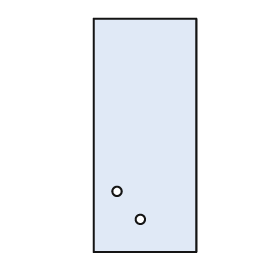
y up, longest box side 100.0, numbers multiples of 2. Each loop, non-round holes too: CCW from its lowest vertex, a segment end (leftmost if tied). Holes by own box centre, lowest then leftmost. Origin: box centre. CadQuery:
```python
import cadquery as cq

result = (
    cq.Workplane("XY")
    .moveTo(-22.0, -50.0)
    .lineTo(22.0, -50.0)
    .lineTo(22.0, 50.0)
    .lineTo(-22.0, 50.0)
    .close()
    .moveTo(-2.0, -36.0)
    .circle(2.0)
    .moveTo(-12.0, -24.0)
    .circle(2.0)
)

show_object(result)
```